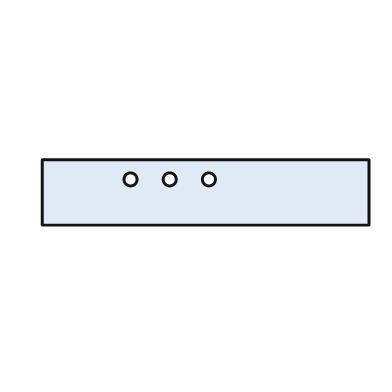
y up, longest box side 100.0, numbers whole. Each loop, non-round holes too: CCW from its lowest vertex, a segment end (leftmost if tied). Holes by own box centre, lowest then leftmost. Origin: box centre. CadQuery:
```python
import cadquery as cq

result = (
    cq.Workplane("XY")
    .moveTo(-50.0, -10.0)
    .lineTo(50.0, -10.0)
    .lineTo(50.0, 10.0)
    .lineTo(-50.0, 10.0)
    .close()
    .moveTo(-23.0, 4.0)
    .circle(2.0)
    .moveTo(-11.0, 4.0)
    .circle(2.0)
    .moveTo(1.0, 4.0)
    .circle(2.0)
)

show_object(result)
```